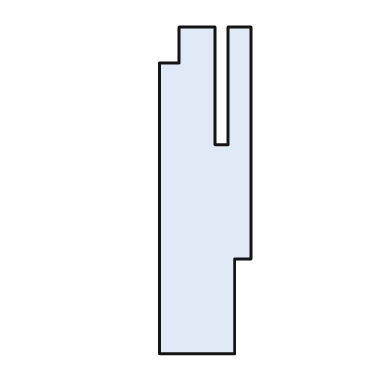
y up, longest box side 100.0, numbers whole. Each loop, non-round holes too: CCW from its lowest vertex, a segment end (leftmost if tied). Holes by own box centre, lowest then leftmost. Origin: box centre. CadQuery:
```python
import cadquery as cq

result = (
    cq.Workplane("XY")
    .moveTo(-14.0, -50.0)
    .lineTo(9.0, -50.0)
    .lineTo(9.0, -21.0)
    .lineTo(14.0, -21.0)
    .lineTo(14.0, 50.0)
    .lineTo(7.0, 50.0)
    .lineTo(7.0, 14.0)
    .lineTo(3.0, 14.0)
    .lineTo(3.0, 50.0)
    .lineTo(-8.0, 50.0)
    .lineTo(-8.0, 39.0)
    .lineTo(-14.0, 39.0)
    .close()
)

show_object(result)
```